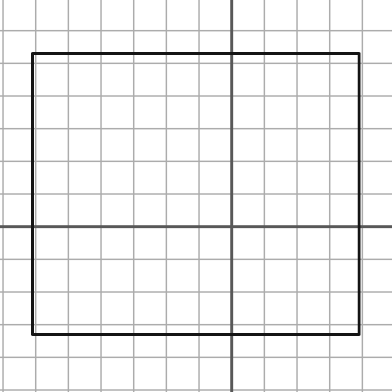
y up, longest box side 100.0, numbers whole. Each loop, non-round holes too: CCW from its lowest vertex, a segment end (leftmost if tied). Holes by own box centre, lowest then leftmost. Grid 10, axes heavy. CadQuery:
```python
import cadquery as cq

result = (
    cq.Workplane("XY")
    .moveTo(-61.0, -33.0)
    .lineTo(39.0, -33.0)
    .lineTo(39.0, 53.0)
    .lineTo(-61.0, 53.0)
    .close()
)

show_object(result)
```